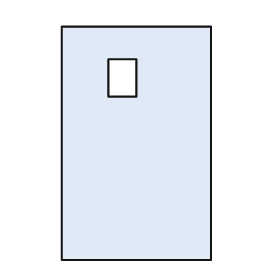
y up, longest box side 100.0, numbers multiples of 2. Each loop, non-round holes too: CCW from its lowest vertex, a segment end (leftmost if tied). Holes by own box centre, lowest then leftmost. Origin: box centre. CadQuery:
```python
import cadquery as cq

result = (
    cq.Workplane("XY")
    .moveTo(-32.0, -50.0)
    .lineTo(32.0, -50.0)
    .lineTo(32.0, 50.0)
    .lineTo(-32.0, 50.0)
    .close()
    .moveTo(-12.0, 20.0)
    .lineTo(0.0, 20.0)
    .lineTo(0.0, 36.0)
    .lineTo(-12.0, 36.0)
    .close()
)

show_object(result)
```